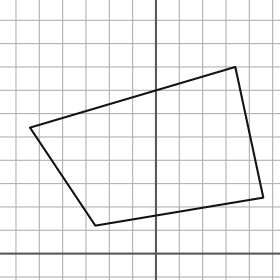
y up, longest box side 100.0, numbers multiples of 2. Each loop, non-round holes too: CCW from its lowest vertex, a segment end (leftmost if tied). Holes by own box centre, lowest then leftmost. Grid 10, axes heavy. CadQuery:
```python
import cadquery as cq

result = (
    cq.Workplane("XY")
    .moveTo(-26.0, 12.0)
    .lineTo(46.0, 24.0)
    .lineTo(34.0, 80.0)
    .lineTo(-54.0, 54.0)
    .close()
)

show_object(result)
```